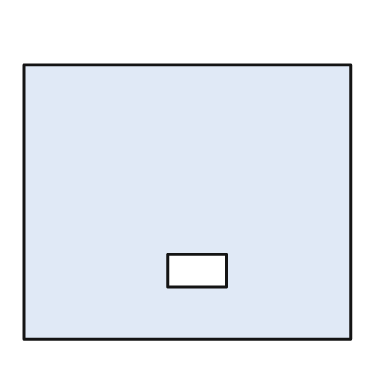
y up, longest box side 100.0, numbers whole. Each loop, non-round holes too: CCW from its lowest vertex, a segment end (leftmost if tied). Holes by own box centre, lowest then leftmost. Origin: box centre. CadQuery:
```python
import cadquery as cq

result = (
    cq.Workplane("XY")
    .moveTo(-50.0, -42.0)
    .lineTo(50.0, -42.0)
    .lineTo(50.0, 42.0)
    .lineTo(-50.0, 42.0)
    .close()
    .moveTo(-6.0, -26.0)
    .lineTo(12.0, -26.0)
    .lineTo(12.0, -16.0)
    .lineTo(-6.0, -16.0)
    .close()
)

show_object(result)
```